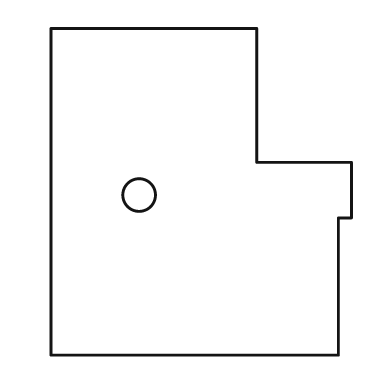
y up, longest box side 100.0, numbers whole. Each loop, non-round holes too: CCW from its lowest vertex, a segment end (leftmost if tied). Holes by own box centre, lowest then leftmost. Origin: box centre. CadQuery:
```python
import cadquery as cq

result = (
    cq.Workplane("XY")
    .moveTo(-46.0, -50.0)
    .lineTo(42.0, -50.0)
    .lineTo(42.0, -8.0)
    .lineTo(46.0, -8.0)
    .lineTo(46.0, 9.0)
    .lineTo(17.0, 9.0)
    .lineTo(17.0, 50.0)
    .lineTo(-46.0, 50.0)
    .close()
    .moveTo(-19.0, -1.0)
    .circle(5.0)
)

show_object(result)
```